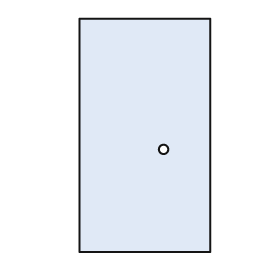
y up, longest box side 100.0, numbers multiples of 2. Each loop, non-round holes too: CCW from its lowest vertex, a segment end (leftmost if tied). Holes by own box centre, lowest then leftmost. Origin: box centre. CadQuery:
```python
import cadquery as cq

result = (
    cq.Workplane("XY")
    .moveTo(-28.0, -50.0)
    .lineTo(28.0, -50.0)
    .lineTo(28.0, 50.0)
    .lineTo(-28.0, 50.0)
    .close()
    .moveTo(8.0, -6.0)
    .circle(2.0)
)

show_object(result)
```